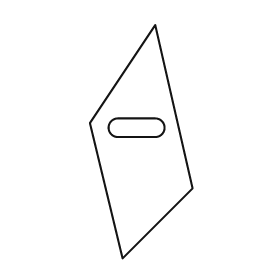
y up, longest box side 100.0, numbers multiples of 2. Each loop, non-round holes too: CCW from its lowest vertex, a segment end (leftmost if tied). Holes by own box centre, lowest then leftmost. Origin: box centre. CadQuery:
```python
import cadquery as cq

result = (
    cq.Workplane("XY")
    .moveTo(-8.0, -50.0)
    .lineTo(22.0, -20.0)
    .lineTo(6.0, 50.0)
    .lineTo(-22.0, 8.0)
    .close()
    .moveTo(-10.0, 2.0)
    .lineTo(6.0, 2.0)
    .threePointArc((10.0, 6.0), (6.0, 10.0))
    .lineTo(-10.0, 10.0)
    .threePointArc((-14.0, 6.0), (-10.0, 2.0))
    .close()
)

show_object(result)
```